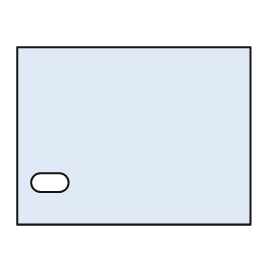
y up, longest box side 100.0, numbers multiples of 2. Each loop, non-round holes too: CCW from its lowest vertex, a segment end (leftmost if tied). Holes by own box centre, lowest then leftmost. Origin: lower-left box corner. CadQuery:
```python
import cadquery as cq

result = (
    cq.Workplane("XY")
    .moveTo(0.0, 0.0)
    .lineTo(100.0, 0.0)
    .lineTo(100.0, 76.0)
    .lineTo(0.0, 76.0)
    .close()
    .moveTo(10.0, 14.0)
    .lineTo(18.0, 14.0)
    .threePointArc((22.0, 18.0), (18.0, 22.0))
    .lineTo(10.0, 22.0)
    .threePointArc((6.0, 18.0), (10.0, 14.0))
    .close()
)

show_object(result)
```